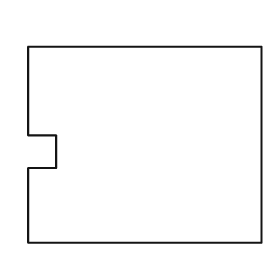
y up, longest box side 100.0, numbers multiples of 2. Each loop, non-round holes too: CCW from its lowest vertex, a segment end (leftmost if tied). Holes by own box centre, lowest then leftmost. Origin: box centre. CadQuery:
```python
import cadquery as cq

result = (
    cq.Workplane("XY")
    .moveTo(-50.0, -42.0)
    .lineTo(50.0, -42.0)
    .lineTo(50.0, 42.0)
    .lineTo(-50.0, 42.0)
    .lineTo(-50.0, 4.0)
    .lineTo(-38.0, 4.0)
    .lineTo(-38.0, -10.0)
    .lineTo(-50.0, -10.0)
    .close()
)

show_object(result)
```